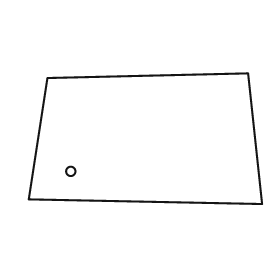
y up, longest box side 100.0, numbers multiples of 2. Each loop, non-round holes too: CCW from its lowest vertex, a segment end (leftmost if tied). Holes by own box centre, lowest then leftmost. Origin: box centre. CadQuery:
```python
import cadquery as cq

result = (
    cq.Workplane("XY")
    .moveTo(50.0, -28.0)
    .lineTo(44.0, 28.0)
    .lineTo(-42.0, 26.0)
    .lineTo(-50.0, -26.0)
    .close()
    .moveTo(-32.0, -14.0)
    .circle(2.0)
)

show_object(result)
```